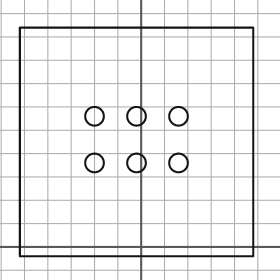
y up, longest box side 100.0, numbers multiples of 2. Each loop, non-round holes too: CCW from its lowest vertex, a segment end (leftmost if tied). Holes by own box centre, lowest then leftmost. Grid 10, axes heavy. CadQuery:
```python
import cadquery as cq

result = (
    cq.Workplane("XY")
    .moveTo(-52.0, -4.0)
    .lineTo(48.0, -4.0)
    .lineTo(48.0, 94.0)
    .lineTo(-52.0, 94.0)
    .close()
    .moveTo(-20.0, 36.0)
    .circle(4.0)
    .moveTo(-2.0, 36.0)
    .circle(4.0)
    .moveTo(16.0, 36.0)
    .circle(4.0)
    .moveTo(-20.0, 56.0)
    .circle(4.0)
    .moveTo(-2.0, 56.0)
    .circle(4.0)
    .moveTo(16.0, 56.0)
    .circle(4.0)
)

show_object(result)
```